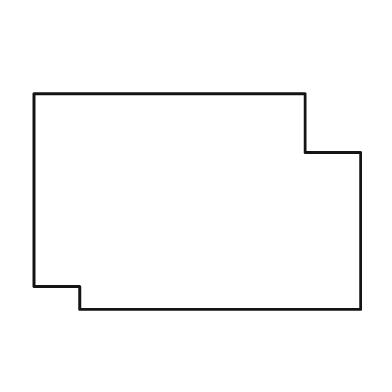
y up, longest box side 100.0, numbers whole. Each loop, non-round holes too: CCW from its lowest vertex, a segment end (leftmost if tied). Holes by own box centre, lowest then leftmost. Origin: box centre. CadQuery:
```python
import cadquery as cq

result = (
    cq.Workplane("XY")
    .moveTo(-36.0, -33.0)
    .lineTo(50.0, -33.0)
    .lineTo(50.0, 15.0)
    .lineTo(33.0, 15.0)
    .lineTo(33.0, 33.0)
    .lineTo(-50.0, 33.0)
    .lineTo(-50.0, -26.0)
    .lineTo(-36.0, -26.0)
    .close()
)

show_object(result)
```